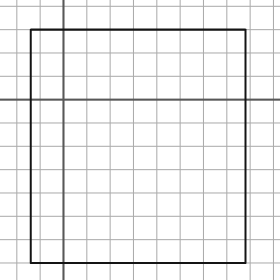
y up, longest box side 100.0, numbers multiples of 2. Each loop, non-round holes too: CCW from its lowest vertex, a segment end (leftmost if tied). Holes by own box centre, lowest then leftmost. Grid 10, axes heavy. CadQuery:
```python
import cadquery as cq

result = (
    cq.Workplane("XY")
    .moveTo(-14.0, -70.0)
    .lineTo(78.0, -70.0)
    .lineTo(78.0, 30.0)
    .lineTo(-14.0, 30.0)
    .close()
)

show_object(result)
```